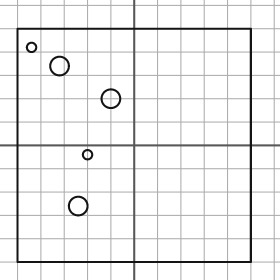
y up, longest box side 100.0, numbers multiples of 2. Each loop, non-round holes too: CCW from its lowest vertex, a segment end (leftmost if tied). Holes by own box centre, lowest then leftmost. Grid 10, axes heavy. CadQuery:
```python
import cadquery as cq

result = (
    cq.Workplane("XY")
    .moveTo(-50.0, -50.0)
    .lineTo(50.0, -50.0)
    .lineTo(50.0, 50.0)
    .lineTo(-50.0, 50.0)
    .close()
    .moveTo(-24.0, -26.0)
    .circle(4.0)
    .moveTo(-20.0, -4.0)
    .circle(2.0)
    .moveTo(-10.0, 20.0)
    .circle(4.0)
    .moveTo(-32.0, 34.0)
    .circle(4.0)
    .moveTo(-44.0, 42.0)
    .circle(2.0)
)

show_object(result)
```